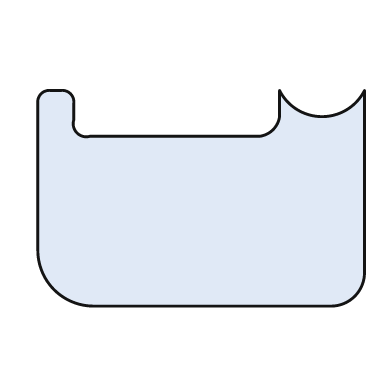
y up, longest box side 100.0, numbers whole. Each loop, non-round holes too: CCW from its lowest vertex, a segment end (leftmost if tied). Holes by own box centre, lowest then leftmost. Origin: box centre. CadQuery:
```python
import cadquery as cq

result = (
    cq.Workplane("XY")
    .moveTo(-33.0, -33.0)
    .lineTo(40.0, -33.0)
    .threePointArc((47.0, -30.0), (50.0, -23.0))
    .lineTo(50.0, 33.0)
    .threePointArc((37.0, 25.0), (24.0, 33.0))
    .lineTo(24.0, 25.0)
    .threePointArc((22.0, 21.0), (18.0, 19.0))
    .lineTo(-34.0, 19.0)
    .threePointArc((-38.0, 20.0), (-39.0, 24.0))
    .lineTo(-39.0, 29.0)
    .threePointArc((-40.0, 32.0), (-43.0, 33.0))
    .lineTo(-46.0, 33.0)
    .threePointArc((-49.0, 32.0), (-50.0, 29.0))
    .lineTo(-50.0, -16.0)
    .threePointArc((-45.0, -28.0), (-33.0, -33.0))
    .close()
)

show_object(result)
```